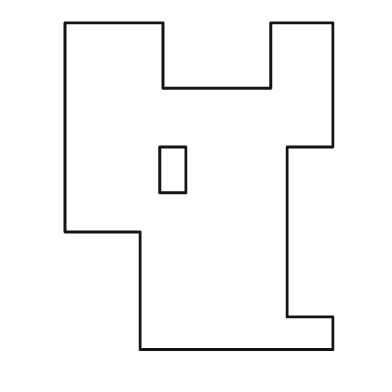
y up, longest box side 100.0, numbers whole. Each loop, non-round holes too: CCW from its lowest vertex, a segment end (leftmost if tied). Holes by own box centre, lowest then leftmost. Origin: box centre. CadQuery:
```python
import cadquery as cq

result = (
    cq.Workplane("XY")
    .moveTo(-18.0, -50.0)
    .lineTo(41.0, -50.0)
    .lineTo(41.0, -40.0)
    .lineTo(27.0, -40.0)
    .lineTo(27.0, 12.0)
    .lineTo(41.0, 12.0)
    .lineTo(41.0, 50.0)
    .lineTo(22.0, 50.0)
    .lineTo(22.0, 30.0)
    .lineTo(-11.0, 30.0)
    .lineTo(-11.0, 50.0)
    .lineTo(-41.0, 50.0)
    .lineTo(-41.0, -14.0)
    .lineTo(-18.0, -14.0)
    .close()
    .moveTo(-12.0, -2.0)
    .lineTo(-4.0, -2.0)
    .lineTo(-4.0, 12.0)
    .lineTo(-12.0, 12.0)
    .close()
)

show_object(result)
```